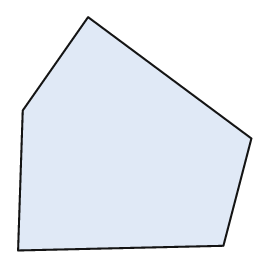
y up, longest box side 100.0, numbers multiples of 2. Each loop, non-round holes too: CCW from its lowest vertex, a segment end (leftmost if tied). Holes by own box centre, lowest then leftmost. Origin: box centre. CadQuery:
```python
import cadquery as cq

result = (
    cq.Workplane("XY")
    .moveTo(-50.0, -50.0)
    .lineTo(38.0, -48.0)
    .lineTo(50.0, -2.0)
    .lineTo(-20.0, 50.0)
    .lineTo(-48.0, 10.0)
    .close()
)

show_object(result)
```